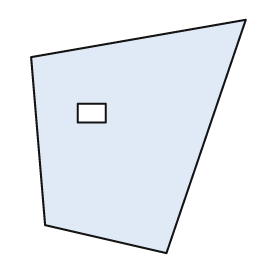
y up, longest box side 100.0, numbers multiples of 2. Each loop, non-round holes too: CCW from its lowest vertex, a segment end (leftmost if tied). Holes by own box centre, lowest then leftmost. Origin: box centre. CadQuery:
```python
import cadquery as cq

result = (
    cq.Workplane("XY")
    .moveTo(12.0, -50.0)
    .lineTo(46.0, 50.0)
    .lineTo(-46.0, 34.0)
    .lineTo(-40.0, -38.0)
    .close()
    .moveTo(-26.0, 6.0)
    .lineTo(-14.0, 6.0)
    .lineTo(-14.0, 14.0)
    .lineTo(-26.0, 14.0)
    .close()
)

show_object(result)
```